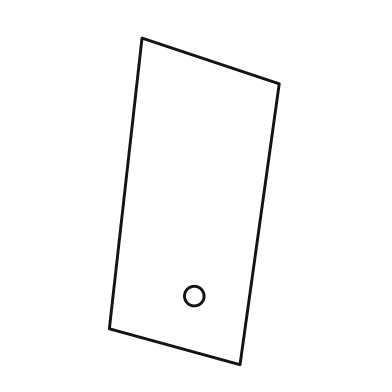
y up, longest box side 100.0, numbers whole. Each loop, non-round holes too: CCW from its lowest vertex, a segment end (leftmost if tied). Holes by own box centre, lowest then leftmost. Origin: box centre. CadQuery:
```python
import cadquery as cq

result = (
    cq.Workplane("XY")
    .moveTo(14.0, -50.0)
    .lineTo(26.0, 36.0)
    .lineTo(-16.0, 50.0)
    .lineTo(-26.0, -39.0)
    .close()
    .moveTo(0.0, -29.0)
    .circle(3.0)
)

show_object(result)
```